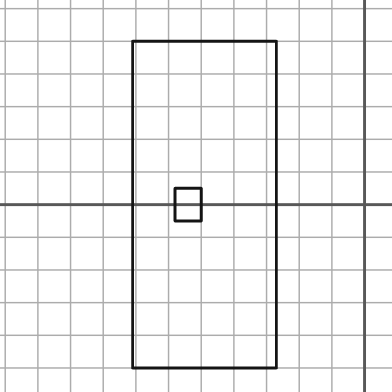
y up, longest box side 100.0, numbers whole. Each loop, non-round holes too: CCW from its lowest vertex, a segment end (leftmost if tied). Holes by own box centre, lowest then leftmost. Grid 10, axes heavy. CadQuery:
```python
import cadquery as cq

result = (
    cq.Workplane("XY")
    .moveTo(-71.0, -50.0)
    .lineTo(-27.0, -50.0)
    .lineTo(-27.0, 50.0)
    .lineTo(-71.0, 50.0)
    .close()
    .moveTo(-58.0, -5.0)
    .lineTo(-50.0, -5.0)
    .lineTo(-50.0, 5.0)
    .lineTo(-58.0, 5.0)
    .close()
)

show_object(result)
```